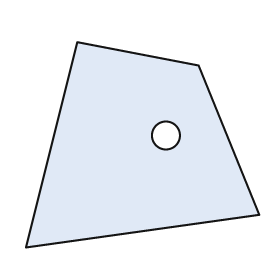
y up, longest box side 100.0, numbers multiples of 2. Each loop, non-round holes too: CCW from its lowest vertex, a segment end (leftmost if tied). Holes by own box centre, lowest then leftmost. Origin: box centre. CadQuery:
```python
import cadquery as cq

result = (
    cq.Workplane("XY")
    .moveTo(-50.0, -44.0)
    .lineTo(50.0, -30.0)
    .lineTo(24.0, 34.0)
    .lineTo(-28.0, 44.0)
    .close()
    .moveTo(10.0, 4.0)
    .circle(6.0)
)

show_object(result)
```